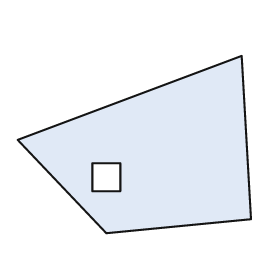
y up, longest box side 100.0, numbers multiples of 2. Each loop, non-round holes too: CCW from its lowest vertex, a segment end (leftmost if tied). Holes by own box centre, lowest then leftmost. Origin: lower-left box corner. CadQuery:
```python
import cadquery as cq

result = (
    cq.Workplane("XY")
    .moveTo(38.0, 0.0)
    .lineTo(100.0, 6.0)
    .lineTo(96.0, 76.0)
    .lineTo(0.0, 40.0)
    .close()
    .moveTo(32.0, 18.0)
    .lineTo(44.0, 18.0)
    .lineTo(44.0, 30.0)
    .lineTo(32.0, 30.0)
    .close()
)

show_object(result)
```